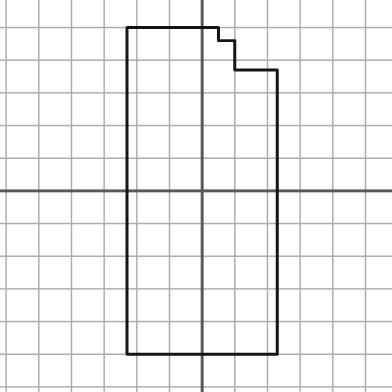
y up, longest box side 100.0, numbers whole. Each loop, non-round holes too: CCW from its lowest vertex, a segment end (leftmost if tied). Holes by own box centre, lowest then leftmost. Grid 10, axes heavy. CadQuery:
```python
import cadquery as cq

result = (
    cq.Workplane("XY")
    .moveTo(-23.0, -50.0)
    .lineTo(23.0, -50.0)
    .lineTo(23.0, 37.0)
    .lineTo(10.0, 37.0)
    .lineTo(10.0, 46.0)
    .lineTo(5.0, 46.0)
    .lineTo(5.0, 50.0)
    .lineTo(-23.0, 50.0)
    .close()
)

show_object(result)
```